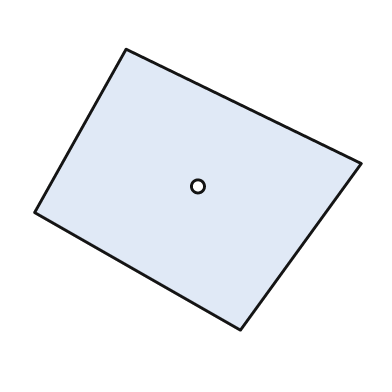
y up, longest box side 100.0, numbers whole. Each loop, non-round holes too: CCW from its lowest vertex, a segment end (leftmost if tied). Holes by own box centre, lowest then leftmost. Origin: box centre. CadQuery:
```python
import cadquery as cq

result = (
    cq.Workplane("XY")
    .moveTo(13.0, -43.0)
    .lineTo(50.0, 8.0)
    .lineTo(-22.0, 43.0)
    .lineTo(-50.0, -7.0)
    .close()
    .moveTo(0.0, 1.0)
    .circle(2.0)
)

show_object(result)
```